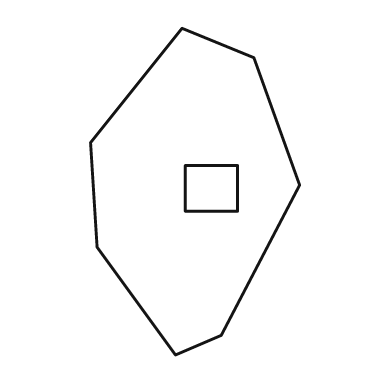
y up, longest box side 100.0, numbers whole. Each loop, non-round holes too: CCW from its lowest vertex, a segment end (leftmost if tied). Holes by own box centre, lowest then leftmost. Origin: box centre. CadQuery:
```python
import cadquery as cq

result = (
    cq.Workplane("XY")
    .moveTo(-6.0, -50.0)
    .lineTo(8.0, -44.0)
    .lineTo(32.0, 2.0)
    .lineTo(18.0, 41.0)
    .lineTo(-4.0, 50.0)
    .lineTo(-32.0, 15.0)
    .lineTo(-30.0, -17.0)
    .close()
    .moveTo(-3.0, -6.0)
    .lineTo(13.0, -6.0)
    .lineTo(13.0, 8.0)
    .lineTo(-3.0, 8.0)
    .close()
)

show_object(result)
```